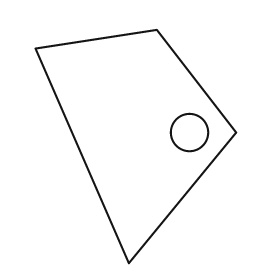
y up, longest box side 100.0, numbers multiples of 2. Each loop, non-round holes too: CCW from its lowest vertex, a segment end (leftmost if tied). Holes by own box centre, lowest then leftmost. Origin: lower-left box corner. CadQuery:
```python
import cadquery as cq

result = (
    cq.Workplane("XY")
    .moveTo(40.0, 0.0)
    .lineTo(86.0, 56.0)
    .lineTo(52.0, 100.0)
    .lineTo(0.0, 92.0)
    .close()
    .moveTo(66.0, 56.0)
    .circle(8.0)
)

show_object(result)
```